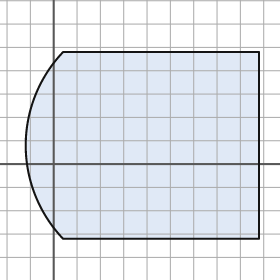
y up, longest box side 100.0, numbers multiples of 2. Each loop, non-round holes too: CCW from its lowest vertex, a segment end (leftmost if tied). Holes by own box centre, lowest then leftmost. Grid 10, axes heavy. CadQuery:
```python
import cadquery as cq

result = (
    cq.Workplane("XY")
    .moveTo(4.0, -32.0)
    .lineTo(88.0, -32.0)
    .lineTo(88.0, 48.0)
    .lineTo(4.0, 48.0)
    .threePointArc((-12.0, 8.0), (4.0, -32.0))
    .close()
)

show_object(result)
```